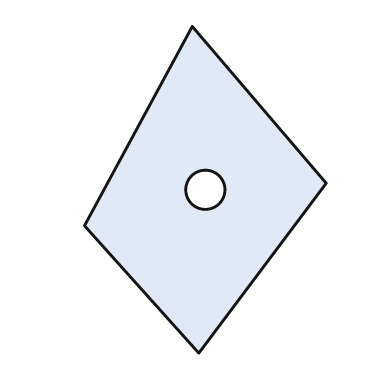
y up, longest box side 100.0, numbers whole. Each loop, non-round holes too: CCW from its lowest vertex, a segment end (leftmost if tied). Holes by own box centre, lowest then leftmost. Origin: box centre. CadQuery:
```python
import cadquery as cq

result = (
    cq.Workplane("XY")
    .moveTo(-2.0, -50.0)
    .lineTo(37.0, 2.0)
    .lineTo(-4.0, 50.0)
    .lineTo(-37.0, -11.0)
    .close()
    .moveTo(0.0, 0.0)
    .circle(6.0)
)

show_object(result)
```